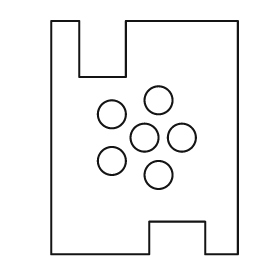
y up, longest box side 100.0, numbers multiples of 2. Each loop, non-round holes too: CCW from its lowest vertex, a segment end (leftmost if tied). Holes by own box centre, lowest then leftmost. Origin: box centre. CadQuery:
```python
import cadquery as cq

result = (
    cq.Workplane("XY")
    .moveTo(-40.0, -50.0)
    .lineTo(2.0, -50.0)
    .lineTo(2.0, -36.0)
    .lineTo(26.0, -36.0)
    .lineTo(26.0, -50.0)
    .lineTo(40.0, -50.0)
    .lineTo(40.0, 50.0)
    .lineTo(-8.0, 50.0)
    .lineTo(-8.0, 26.0)
    .lineTo(-28.0, 26.0)
    .lineTo(-28.0, 50.0)
    .lineTo(-40.0, 50.0)
    .close()
    .moveTo(6.0, -16.0)
    .circle(6.0)
    .moveTo(-14.0, -10.0)
    .circle(6.0)
    .moveTo(0.0, 0.0)
    .circle(6.0)
    .moveTo(16.0, 0.0)
    .circle(6.0)
    .moveTo(-14.0, 10.0)
    .circle(6.0)
    .moveTo(6.0, 16.0)
    .circle(6.0)
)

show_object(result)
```